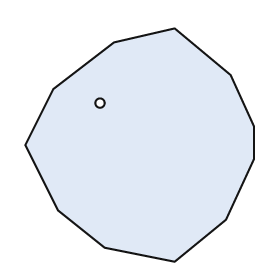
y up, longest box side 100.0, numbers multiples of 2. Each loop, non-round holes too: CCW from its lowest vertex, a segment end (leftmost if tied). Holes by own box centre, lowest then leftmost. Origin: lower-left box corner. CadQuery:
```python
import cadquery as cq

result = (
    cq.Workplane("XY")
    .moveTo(64.0, 0.0)
    .lineTo(86.0, 18.0)
    .lineTo(98.0, 44.0)
    .lineTo(98.0, 58.0)
    .lineTo(88.0, 80.0)
    .lineTo(64.0, 100.0)
    .lineTo(38.0, 94.0)
    .lineTo(12.0, 74.0)
    .lineTo(0.0, 50.0)
    .lineTo(14.0, 22.0)
    .lineTo(34.0, 6.0)
    .close()
    .moveTo(32.0, 68.0)
    .circle(2.0)
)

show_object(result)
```